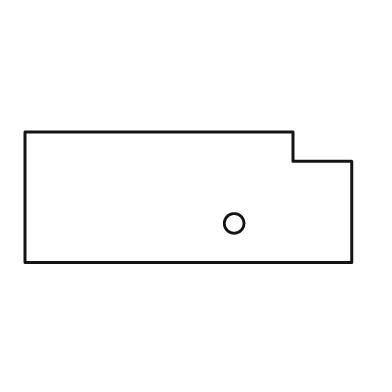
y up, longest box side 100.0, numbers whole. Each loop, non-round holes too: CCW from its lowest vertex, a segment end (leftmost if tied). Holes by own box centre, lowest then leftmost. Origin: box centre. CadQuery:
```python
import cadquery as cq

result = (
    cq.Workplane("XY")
    .moveTo(-50.0, -20.0)
    .lineTo(50.0, -20.0)
    .lineTo(50.0, 11.0)
    .lineTo(32.0, 11.0)
    .lineTo(32.0, 20.0)
    .lineTo(-50.0, 20.0)
    .close()
    .moveTo(14.0, -8.0)
    .circle(3.0)
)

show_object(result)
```